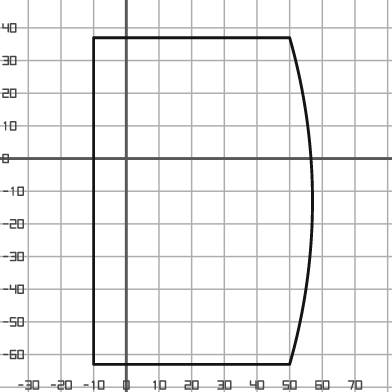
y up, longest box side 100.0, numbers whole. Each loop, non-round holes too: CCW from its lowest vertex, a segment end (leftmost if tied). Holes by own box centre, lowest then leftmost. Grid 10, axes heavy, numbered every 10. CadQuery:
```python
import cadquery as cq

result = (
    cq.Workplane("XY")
    .moveTo(-10.0, -63.0)
    .lineTo(50.0, -63.0)
    .threePointArc((57.0, -13.0), (50.0, 37.0))
    .lineTo(-10.0, 37.0)
    .close()
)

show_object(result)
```